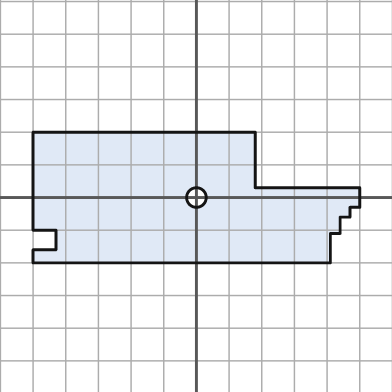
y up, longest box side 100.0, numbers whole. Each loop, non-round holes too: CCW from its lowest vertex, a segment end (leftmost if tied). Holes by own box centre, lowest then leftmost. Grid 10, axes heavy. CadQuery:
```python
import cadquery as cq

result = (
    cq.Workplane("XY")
    .moveTo(-50.0, -20.0)
    .lineTo(41.0, -20.0)
    .lineTo(41.0, -11.0)
    .lineTo(44.0, -11.0)
    .lineTo(44.0, -6.0)
    .lineTo(47.0, -6.0)
    .lineTo(47.0, -3.0)
    .lineTo(50.0, -3.0)
    .lineTo(50.0, 3.0)
    .lineTo(18.0, 3.0)
    .lineTo(18.0, 20.0)
    .lineTo(-50.0, 20.0)
    .lineTo(-50.0, -10.0)
    .lineTo(-43.0, -10.0)
    .lineTo(-43.0, -16.0)
    .lineTo(-50.0, -16.0)
    .close()
    .moveTo(0.0, 0.0)
    .circle(3.0)
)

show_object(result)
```